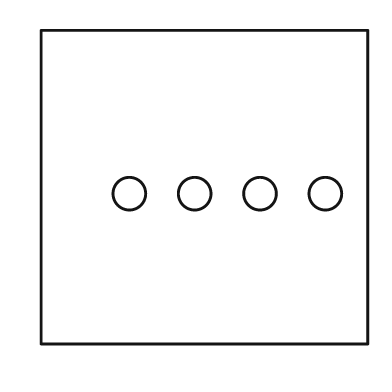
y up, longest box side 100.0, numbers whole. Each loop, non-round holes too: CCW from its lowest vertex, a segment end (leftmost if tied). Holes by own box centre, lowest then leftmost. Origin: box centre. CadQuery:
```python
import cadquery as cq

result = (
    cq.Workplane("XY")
    .moveTo(-50.0, -48.0)
    .lineTo(50.0, -48.0)
    .lineTo(50.0, 48.0)
    .lineTo(-50.0, 48.0)
    .close()
    .moveTo(-23.0, -2.0)
    .circle(5.0)
    .moveTo(-3.0, -2.0)
    .circle(5.0)
    .moveTo(17.0, -2.0)
    .circle(5.0)
    .moveTo(37.0, -2.0)
    .circle(5.0)
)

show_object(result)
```